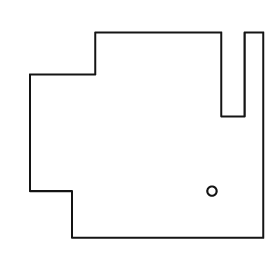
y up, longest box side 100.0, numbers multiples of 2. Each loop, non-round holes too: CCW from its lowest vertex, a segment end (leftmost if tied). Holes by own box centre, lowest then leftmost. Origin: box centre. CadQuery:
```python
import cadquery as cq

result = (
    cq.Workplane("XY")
    .moveTo(-32.0, -44.0)
    .lineTo(50.0, -44.0)
    .lineTo(50.0, 44.0)
    .lineTo(42.0, 44.0)
    .lineTo(42.0, 8.0)
    .lineTo(32.0, 8.0)
    .lineTo(32.0, 44.0)
    .lineTo(-22.0, 44.0)
    .lineTo(-22.0, 26.0)
    .lineTo(-50.0, 26.0)
    .lineTo(-50.0, -24.0)
    .lineTo(-32.0, -24.0)
    .close()
    .moveTo(28.0, -24.0)
    .circle(2.0)
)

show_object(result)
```